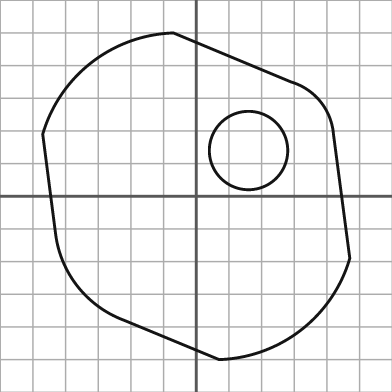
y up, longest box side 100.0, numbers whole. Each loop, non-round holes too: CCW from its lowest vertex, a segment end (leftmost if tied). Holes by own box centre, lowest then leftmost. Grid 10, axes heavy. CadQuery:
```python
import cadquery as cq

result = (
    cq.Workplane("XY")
    .moveTo(7.0, -50.0)
    .threePointArc((32.0, -41.0), (47.0, -19.0))
    .lineTo(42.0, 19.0)
    .threePointArc((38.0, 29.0), (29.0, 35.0))
    .lineTo(-7.0, 50.0)
    .threePointArc((-32.0, 41.0), (-47.0, 19.0))
    .lineTo(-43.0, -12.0)
    .threePointArc((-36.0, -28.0), (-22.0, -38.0))
    .close()
    .moveTo(16.0, 14.0)
    .circle(12.0)
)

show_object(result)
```